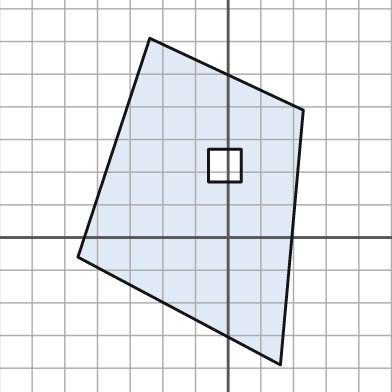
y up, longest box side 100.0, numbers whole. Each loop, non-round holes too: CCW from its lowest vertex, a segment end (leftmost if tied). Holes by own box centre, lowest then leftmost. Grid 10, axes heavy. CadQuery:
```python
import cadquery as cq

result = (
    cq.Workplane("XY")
    .moveTo(16.0, -39.0)
    .lineTo(23.0, 39.0)
    .lineTo(-24.0, 61.0)
    .lineTo(-46.0, -6.0)
    .close()
    .moveTo(-6.0, 17.0)
    .lineTo(4.0, 17.0)
    .lineTo(4.0, 27.0)
    .lineTo(-6.0, 27.0)
    .close()
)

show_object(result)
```